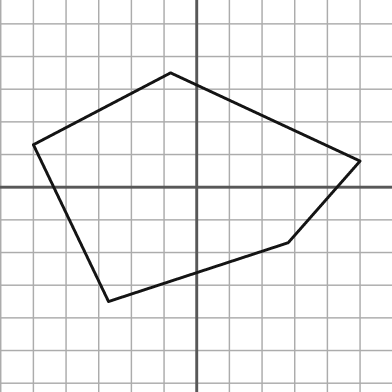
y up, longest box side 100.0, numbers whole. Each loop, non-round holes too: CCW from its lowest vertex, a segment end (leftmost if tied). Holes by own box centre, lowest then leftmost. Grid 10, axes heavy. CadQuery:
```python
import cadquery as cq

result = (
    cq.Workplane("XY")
    .moveTo(-27.0, -35.0)
    .lineTo(28.0, -17.0)
    .lineTo(50.0, 8.0)
    .lineTo(-8.0, 35.0)
    .lineTo(-50.0, 13.0)
    .close()
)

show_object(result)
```